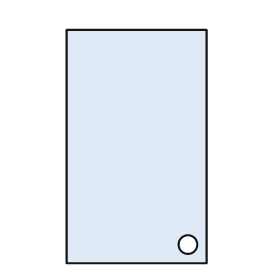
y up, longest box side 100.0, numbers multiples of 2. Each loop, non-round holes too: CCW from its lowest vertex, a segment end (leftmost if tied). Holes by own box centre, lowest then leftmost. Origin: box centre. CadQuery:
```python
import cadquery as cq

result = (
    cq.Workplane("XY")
    .moveTo(-30.0, -50.0)
    .lineTo(30.0, -50.0)
    .lineTo(30.0, 50.0)
    .lineTo(-30.0, 50.0)
    .close()
    .moveTo(22.0, -42.0)
    .circle(4.0)
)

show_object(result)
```